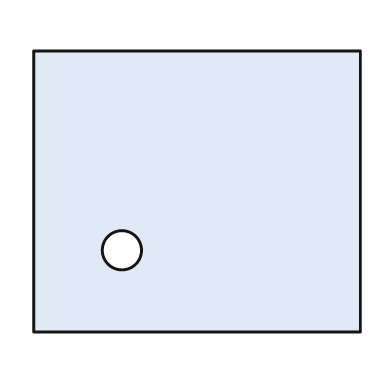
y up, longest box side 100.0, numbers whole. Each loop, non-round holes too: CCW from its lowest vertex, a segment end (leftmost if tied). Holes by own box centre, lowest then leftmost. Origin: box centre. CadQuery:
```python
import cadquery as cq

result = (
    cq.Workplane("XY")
    .moveTo(-50.0, -43.0)
    .lineTo(50.0, -43.0)
    .lineTo(50.0, 43.0)
    .lineTo(-50.0, 43.0)
    .close()
    .moveTo(-23.0, -18.0)
    .circle(6.0)
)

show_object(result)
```